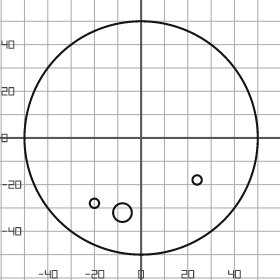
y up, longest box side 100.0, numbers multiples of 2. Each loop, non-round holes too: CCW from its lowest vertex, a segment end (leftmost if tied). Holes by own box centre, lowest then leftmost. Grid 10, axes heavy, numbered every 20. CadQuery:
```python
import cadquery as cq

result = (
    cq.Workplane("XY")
    .moveTo(0.0, 0.0)
    .circle(50.0)
    .moveTo(-8.0, -32.0)
    .circle(4.0)
    .moveTo(-20.0, -28.0)
    .circle(2.0)
    .moveTo(24.0, -18.0)
    .circle(2.0)
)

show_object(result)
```